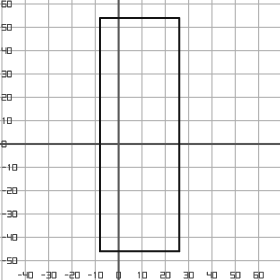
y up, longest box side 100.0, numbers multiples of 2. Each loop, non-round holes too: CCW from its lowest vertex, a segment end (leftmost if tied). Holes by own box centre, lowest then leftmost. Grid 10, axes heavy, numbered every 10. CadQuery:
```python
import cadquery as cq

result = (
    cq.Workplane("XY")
    .moveTo(-8.0, -46.0)
    .lineTo(26.0, -46.0)
    .lineTo(26.0, 54.0)
    .lineTo(-8.0, 54.0)
    .close()
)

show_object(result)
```